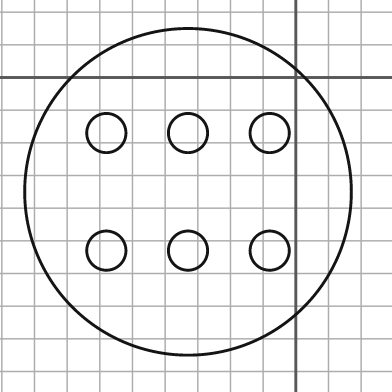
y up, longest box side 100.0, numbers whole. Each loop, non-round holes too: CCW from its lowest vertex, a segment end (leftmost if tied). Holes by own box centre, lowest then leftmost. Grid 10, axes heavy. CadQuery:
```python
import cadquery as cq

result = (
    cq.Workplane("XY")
    .moveTo(-33.0, -35.0)
    .circle(50.0)
    .moveTo(-58.0, -53.0)
    .circle(6.0)
    .moveTo(-33.0, -53.0)
    .circle(6.0)
    .moveTo(-8.0, -53.0)
    .circle(6.0)
    .moveTo(-58.0, -17.0)
    .circle(6.0)
    .moveTo(-33.0, -17.0)
    .circle(6.0)
    .moveTo(-8.0, -17.0)
    .circle(6.0)
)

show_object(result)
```